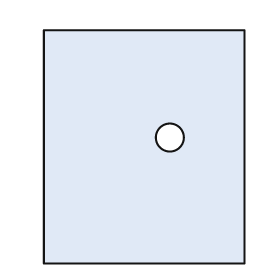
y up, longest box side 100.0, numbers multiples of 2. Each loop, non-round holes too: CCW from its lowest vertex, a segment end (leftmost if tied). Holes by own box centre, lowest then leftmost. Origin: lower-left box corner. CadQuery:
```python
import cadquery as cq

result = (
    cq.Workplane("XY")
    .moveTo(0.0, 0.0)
    .lineTo(86.0, 0.0)
    .lineTo(86.0, 100.0)
    .lineTo(0.0, 100.0)
    .close()
    .moveTo(54.0, 54.0)
    .circle(6.0)
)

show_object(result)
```